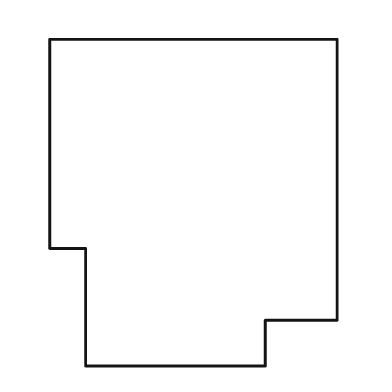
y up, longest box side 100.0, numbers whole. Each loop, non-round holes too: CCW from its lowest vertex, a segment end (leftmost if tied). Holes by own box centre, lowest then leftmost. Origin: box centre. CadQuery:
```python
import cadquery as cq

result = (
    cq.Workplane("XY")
    .moveTo(-33.0, -50.0)
    .lineTo(22.0, -50.0)
    .lineTo(22.0, -36.0)
    .lineTo(44.0, -36.0)
    .lineTo(44.0, 50.0)
    .lineTo(-44.0, 50.0)
    .lineTo(-44.0, -14.0)
    .lineTo(-33.0, -14.0)
    .close()
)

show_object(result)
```